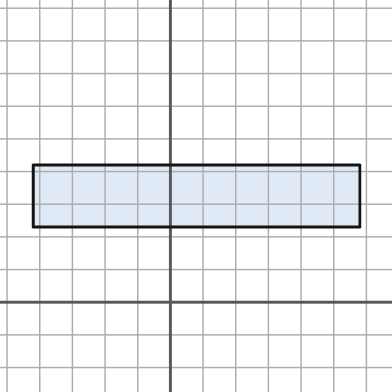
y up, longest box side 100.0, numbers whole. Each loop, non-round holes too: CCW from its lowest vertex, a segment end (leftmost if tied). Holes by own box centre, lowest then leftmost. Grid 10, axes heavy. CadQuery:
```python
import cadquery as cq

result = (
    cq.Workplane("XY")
    .moveTo(-42.0, 23.0)
    .lineTo(58.0, 23.0)
    .lineTo(58.0, 42.0)
    .lineTo(-42.0, 42.0)
    .close()
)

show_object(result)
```